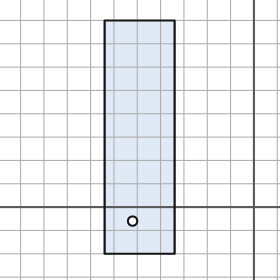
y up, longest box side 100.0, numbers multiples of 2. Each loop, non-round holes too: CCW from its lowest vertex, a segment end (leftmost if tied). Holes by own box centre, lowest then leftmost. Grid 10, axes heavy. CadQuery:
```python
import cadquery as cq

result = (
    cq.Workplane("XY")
    .moveTo(-64.0, -20.0)
    .lineTo(-34.0, -20.0)
    .lineTo(-34.0, 80.0)
    .lineTo(-64.0, 80.0)
    .close()
    .moveTo(-52.0, -6.0)
    .circle(2.0)
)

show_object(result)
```